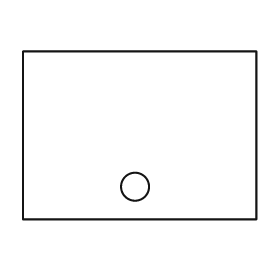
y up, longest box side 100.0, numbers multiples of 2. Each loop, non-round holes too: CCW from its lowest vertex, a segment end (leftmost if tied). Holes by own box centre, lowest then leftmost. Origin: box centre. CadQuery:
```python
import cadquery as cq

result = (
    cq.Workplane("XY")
    .moveTo(-50.0, -36.0)
    .lineTo(50.0, -36.0)
    .lineTo(50.0, 36.0)
    .lineTo(-50.0, 36.0)
    .close()
    .moveTo(-2.0, -22.0)
    .circle(6.0)
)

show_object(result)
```